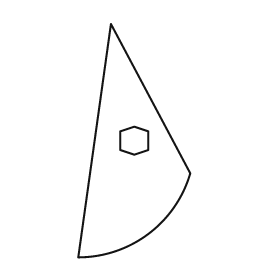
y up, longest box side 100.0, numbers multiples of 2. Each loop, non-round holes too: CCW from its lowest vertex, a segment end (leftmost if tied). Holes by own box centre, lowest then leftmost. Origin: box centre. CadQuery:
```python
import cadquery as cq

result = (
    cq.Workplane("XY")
    .moveTo(-24.0, -50.0)
    .threePointArc((6.0, -40.0), (24.0, -14.0))
    .lineTo(-10.0, 50.0)
    .close()
    .moveTo(0.0, -6.0)
    .lineTo(6.0, -4.0)
    .lineTo(6.0, 4.0)
    .lineTo(0.0, 6.0)
    .lineTo(-6.0, 4.0)
    .lineTo(-6.0, -4.0)
    .close()
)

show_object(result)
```